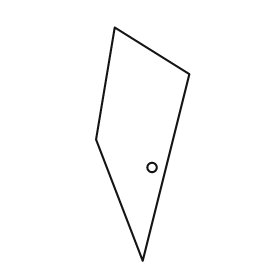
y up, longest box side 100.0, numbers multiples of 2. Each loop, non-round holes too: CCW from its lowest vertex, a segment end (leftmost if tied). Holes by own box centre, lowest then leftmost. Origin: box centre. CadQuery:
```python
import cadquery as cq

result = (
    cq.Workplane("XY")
    .moveTo(0.0, -50.0)
    .lineTo(20.0, 30.0)
    .lineTo(-12.0, 50.0)
    .lineTo(-20.0, 2.0)
    .close()
    .moveTo(4.0, -10.0)
    .circle(2.0)
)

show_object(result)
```